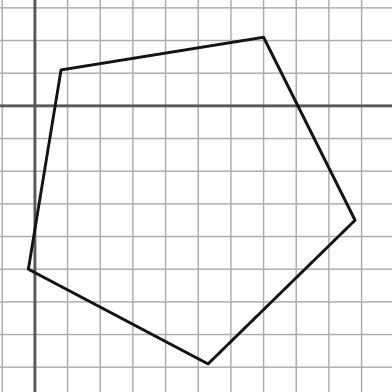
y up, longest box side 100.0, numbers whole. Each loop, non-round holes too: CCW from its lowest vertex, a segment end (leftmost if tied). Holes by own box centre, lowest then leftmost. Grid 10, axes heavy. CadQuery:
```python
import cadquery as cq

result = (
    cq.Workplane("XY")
    .moveTo(53.0, -79.0)
    .lineTo(98.0, -35.0)
    .lineTo(70.0, 21.0)
    .lineTo(8.0, 11.0)
    .lineTo(-2.0, -50.0)
    .close()
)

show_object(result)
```